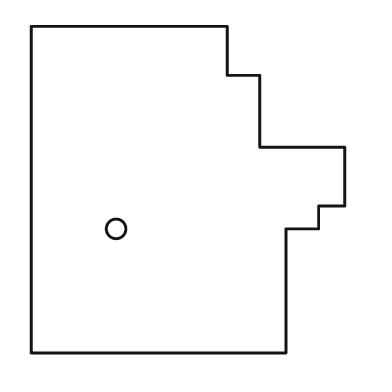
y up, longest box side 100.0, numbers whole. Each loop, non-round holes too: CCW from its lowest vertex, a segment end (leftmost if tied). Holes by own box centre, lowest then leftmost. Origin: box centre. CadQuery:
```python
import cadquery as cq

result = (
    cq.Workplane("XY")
    .moveTo(-48.0, -50.0)
    .lineTo(30.0, -50.0)
    .lineTo(30.0, -12.0)
    .lineTo(40.0, -12.0)
    .lineTo(40.0, -5.0)
    .lineTo(48.0, -5.0)
    .lineTo(48.0, 13.0)
    .lineTo(22.0, 13.0)
    .lineTo(22.0, 35.0)
    .lineTo(12.0, 35.0)
    .lineTo(12.0, 50.0)
    .lineTo(-48.0, 50.0)
    .close()
    .moveTo(-22.0, -12.0)
    .circle(3.0)
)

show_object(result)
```